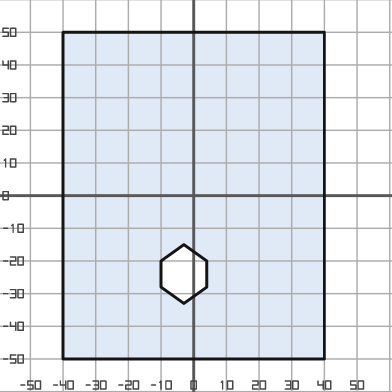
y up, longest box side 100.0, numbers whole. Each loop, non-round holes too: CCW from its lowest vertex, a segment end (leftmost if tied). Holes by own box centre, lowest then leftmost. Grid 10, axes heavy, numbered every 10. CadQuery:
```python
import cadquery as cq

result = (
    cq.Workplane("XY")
    .moveTo(-40.0, -50.0)
    .lineTo(40.0, -50.0)
    .lineTo(40.0, 50.0)
    .lineTo(-40.0, 50.0)
    .close()
    .moveTo(-3.0, -33.0)
    .lineTo(4.0, -28.0)
    .lineTo(4.0, -20.0)
    .lineTo(-3.0, -15.0)
    .lineTo(-10.0, -20.0)
    .lineTo(-10.0, -28.0)
    .close()
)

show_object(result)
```